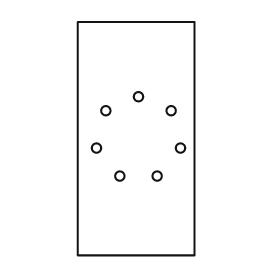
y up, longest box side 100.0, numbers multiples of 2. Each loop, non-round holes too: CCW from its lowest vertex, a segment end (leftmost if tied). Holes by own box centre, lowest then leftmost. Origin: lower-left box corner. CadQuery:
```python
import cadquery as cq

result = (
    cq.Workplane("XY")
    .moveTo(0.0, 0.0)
    .lineTo(50.0, 0.0)
    .lineTo(50.0, 100.0)
    .lineTo(0.0, 100.0)
    .close()
    .moveTo(18.0, 34.0)
    .circle(2.0)
    .moveTo(34.0, 34.0)
    .circle(2.0)
    .moveTo(8.0, 46.0)
    .circle(2.0)
    .moveTo(44.0, 46.0)
    .circle(2.0)
    .moveTo(12.0, 62.0)
    .circle(2.0)
    .moveTo(40.0, 62.0)
    .circle(2.0)
    .moveTo(26.0, 68.0)
    .circle(2.0)
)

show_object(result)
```